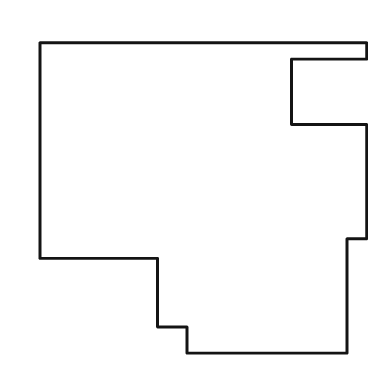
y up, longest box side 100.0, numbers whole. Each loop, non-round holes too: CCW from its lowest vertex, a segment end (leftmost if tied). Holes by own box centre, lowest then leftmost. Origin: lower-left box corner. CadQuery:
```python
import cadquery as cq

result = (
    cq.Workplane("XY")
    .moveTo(45.0, 0.0)
    .lineTo(94.0, 0.0)
    .lineTo(94.0, 35.0)
    .lineTo(100.0, 35.0)
    .lineTo(100.0, 70.0)
    .lineTo(77.0, 70.0)
    .lineTo(77.0, 90.0)
    .lineTo(100.0, 90.0)
    .lineTo(100.0, 95.0)
    .lineTo(0.0, 95.0)
    .lineTo(0.0, 29.0)
    .lineTo(36.0, 29.0)
    .lineTo(36.0, 8.0)
    .lineTo(45.0, 8.0)
    .close()
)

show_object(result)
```